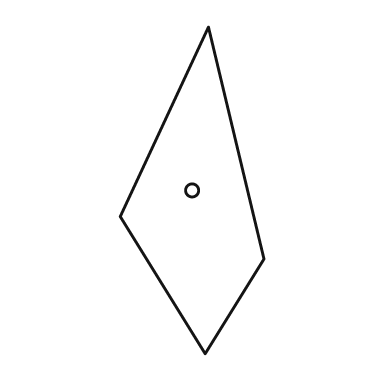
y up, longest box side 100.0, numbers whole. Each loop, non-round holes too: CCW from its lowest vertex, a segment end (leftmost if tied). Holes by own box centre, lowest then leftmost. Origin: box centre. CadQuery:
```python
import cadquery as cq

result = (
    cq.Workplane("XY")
    .moveTo(4.0, -50.0)
    .lineTo(22.0, -21.0)
    .lineTo(5.0, 50.0)
    .lineTo(-22.0, -8.0)
    .close()
    .moveTo(0.0, 0.0)
    .circle(2.0)
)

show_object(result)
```